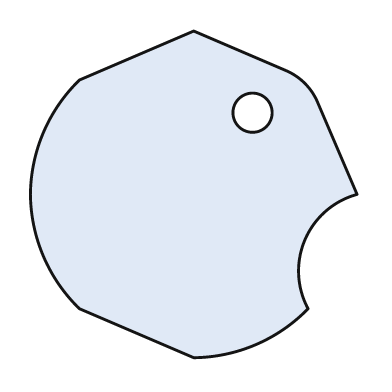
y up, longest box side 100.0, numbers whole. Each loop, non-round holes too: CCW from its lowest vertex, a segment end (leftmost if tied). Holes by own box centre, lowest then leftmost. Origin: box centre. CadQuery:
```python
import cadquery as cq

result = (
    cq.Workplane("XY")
    .moveTo(0.0, -50.0)
    .threePointArc((19.0, -46.0), (35.0, -35.0))
    .threePointArc((34.0, -14.0), (50.0, 0.0))
    .lineTo(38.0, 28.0)
    .threePointArc((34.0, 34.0), (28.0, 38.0))
    .lineTo(0.0, 50.0)
    .lineTo(-35.0, 35.0)
    .threePointArc((-46.0, 19.0), (-50.0, 0.0))
    .threePointArc((-46.0, -19.0), (-35.0, -35.0))
    .close()
    .moveTo(18.0, 25.0)
    .circle(6.0)
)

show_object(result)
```